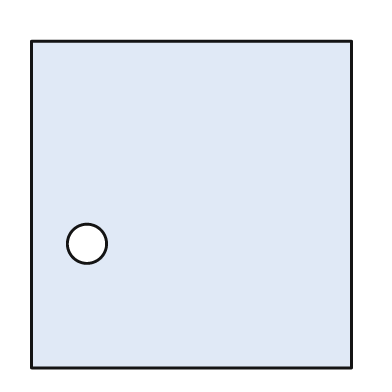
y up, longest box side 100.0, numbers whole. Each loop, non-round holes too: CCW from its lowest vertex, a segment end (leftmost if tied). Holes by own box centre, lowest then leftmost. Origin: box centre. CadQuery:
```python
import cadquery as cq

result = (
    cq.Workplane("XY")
    .moveTo(-49.0, -50.0)
    .lineTo(49.0, -50.0)
    .lineTo(49.0, 50.0)
    .lineTo(-49.0, 50.0)
    .close()
    .moveTo(-32.0, -12.0)
    .circle(6.0)
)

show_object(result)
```